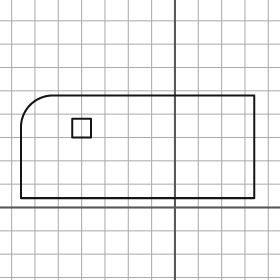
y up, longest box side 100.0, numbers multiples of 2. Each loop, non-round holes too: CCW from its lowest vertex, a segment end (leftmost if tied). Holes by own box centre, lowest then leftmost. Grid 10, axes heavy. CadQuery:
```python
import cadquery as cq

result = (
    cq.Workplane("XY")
    .moveTo(-66.0, 4.0)
    .lineTo(34.0, 4.0)
    .lineTo(34.0, 48.0)
    .lineTo(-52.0, 48.0)
    .threePointArc((-62.0, 44.0), (-66.0, 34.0))
    .close()
    .moveTo(-44.0, 30.0)
    .lineTo(-36.0, 30.0)
    .lineTo(-36.0, 38.0)
    .lineTo(-44.0, 38.0)
    .close()
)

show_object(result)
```